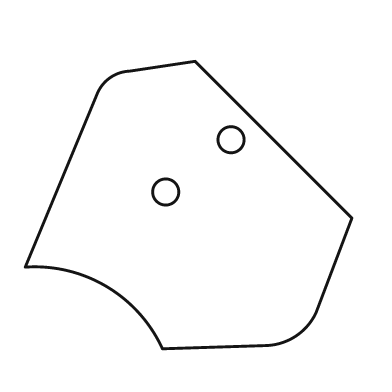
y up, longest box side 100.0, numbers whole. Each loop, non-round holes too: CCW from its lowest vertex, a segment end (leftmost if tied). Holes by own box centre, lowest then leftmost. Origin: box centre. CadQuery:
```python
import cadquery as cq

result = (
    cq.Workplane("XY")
    .moveTo(-8.0, -44.0)
    .lineTo(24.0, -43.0)
    .threePointArc((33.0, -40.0), (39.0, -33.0))
    .lineTo(50.0, -4.0)
    .lineTo(2.0, 44.0)
    .lineTo(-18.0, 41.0)
    .threePointArc((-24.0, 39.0), (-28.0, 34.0))
    .lineTo(-50.0, -19.0)
    .threePointArc((-25.0, -25.0), (-8.0, -44.0))
    .close()
    .moveTo(-7.0, 4.0)
    .circle(4.0)
    .moveTo(13.0, 20.0)
    .circle(4.0)
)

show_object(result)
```